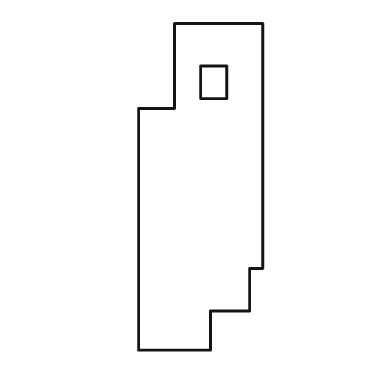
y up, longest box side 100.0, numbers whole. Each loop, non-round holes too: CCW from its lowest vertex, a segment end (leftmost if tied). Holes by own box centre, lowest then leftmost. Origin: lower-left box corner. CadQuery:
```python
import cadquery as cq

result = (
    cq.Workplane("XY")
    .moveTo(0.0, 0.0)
    .lineTo(22.0, 0.0)
    .lineTo(22.0, 12.0)
    .lineTo(34.0, 12.0)
    .lineTo(34.0, 25.0)
    .lineTo(38.0, 25.0)
    .lineTo(38.0, 100.0)
    .lineTo(11.0, 100.0)
    .lineTo(11.0, 74.0)
    .lineTo(0.0, 74.0)
    .close()
    .moveTo(19.0, 77.0)
    .lineTo(27.0, 77.0)
    .lineTo(27.0, 87.0)
    .lineTo(19.0, 87.0)
    .close()
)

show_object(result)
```